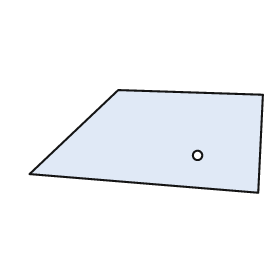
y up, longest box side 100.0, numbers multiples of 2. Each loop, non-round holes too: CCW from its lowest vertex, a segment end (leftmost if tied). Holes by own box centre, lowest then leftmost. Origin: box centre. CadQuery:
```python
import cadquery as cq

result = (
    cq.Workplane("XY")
    .moveTo(48.0, -22.0)
    .lineTo(50.0, 20.0)
    .lineTo(-12.0, 22.0)
    .lineTo(-50.0, -14.0)
    .close()
    .moveTo(22.0, -6.0)
    .circle(2.0)
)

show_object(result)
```